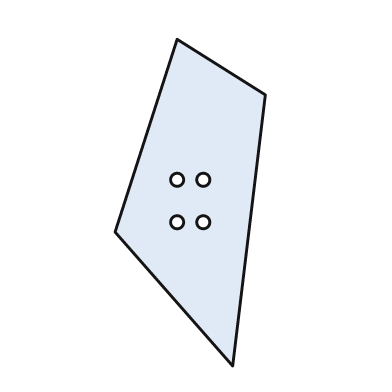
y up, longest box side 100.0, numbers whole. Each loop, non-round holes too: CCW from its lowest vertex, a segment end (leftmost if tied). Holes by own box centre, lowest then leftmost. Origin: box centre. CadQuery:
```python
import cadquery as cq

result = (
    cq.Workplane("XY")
    .moveTo(13.0, -50.0)
    .lineTo(23.0, 33.0)
    .lineTo(-4.0, 50.0)
    .lineTo(-23.0, -9.0)
    .close()
    .moveTo(-4.0, -6.0)
    .circle(2.0)
    .moveTo(4.0, -6.0)
    .circle(2.0)
    .moveTo(-4.0, 7.0)
    .circle(2.0)
    .moveTo(4.0, 7.0)
    .circle(2.0)
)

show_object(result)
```